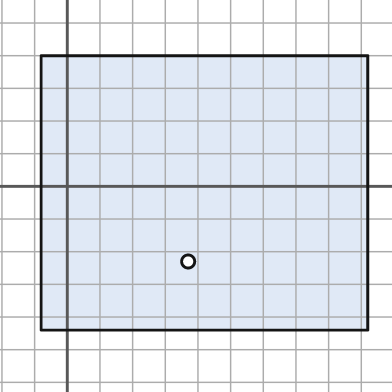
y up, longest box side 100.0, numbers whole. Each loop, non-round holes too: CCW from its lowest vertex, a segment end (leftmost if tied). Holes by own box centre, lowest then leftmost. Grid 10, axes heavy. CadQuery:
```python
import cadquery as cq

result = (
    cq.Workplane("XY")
    .moveTo(-8.0, -44.0)
    .lineTo(92.0, -44.0)
    .lineTo(92.0, 40.0)
    .lineTo(-8.0, 40.0)
    .close()
    .moveTo(37.0, -23.0)
    .circle(2.0)
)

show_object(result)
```